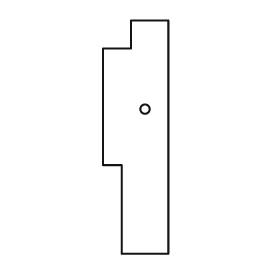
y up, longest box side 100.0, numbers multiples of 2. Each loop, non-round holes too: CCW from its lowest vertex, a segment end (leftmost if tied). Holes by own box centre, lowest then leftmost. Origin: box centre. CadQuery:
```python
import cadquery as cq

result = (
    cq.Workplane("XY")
    .moveTo(-6.0, -50.0)
    .lineTo(14.0, -50.0)
    .lineTo(14.0, 50.0)
    .lineTo(-2.0, 50.0)
    .lineTo(-2.0, 38.0)
    .lineTo(-14.0, 38.0)
    .lineTo(-14.0, -12.0)
    .lineTo(-6.0, -12.0)
    .close()
    .moveTo(4.0, 12.0)
    .circle(2.0)
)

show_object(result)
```